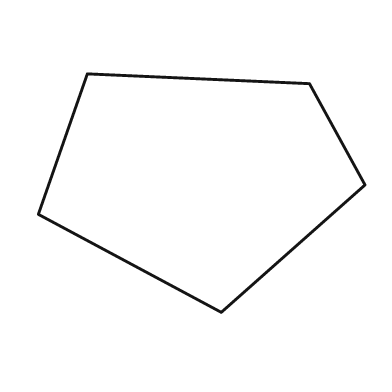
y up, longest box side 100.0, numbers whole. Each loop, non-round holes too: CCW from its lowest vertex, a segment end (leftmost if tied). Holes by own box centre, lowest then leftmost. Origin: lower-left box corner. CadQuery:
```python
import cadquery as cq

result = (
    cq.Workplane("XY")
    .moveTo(56.0, 0.0)
    .lineTo(100.0, 39.0)
    .lineTo(83.0, 70.0)
    .lineTo(15.0, 73.0)
    .lineTo(0.0, 30.0)
    .close()
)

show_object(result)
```